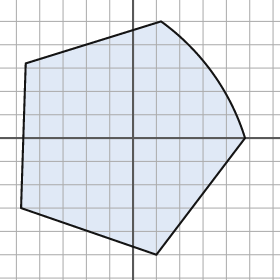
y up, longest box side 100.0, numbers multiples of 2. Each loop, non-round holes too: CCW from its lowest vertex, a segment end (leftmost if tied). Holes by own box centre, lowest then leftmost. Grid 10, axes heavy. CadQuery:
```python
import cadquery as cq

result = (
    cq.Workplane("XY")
    .moveTo(10.0, -50.0)
    .lineTo(48.0, 0.0)
    .threePointArc((34.0, 28.0), (12.0, 50.0))
    .lineTo(-46.0, 32.0)
    .lineTo(-48.0, -30.0)
    .close()
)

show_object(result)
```